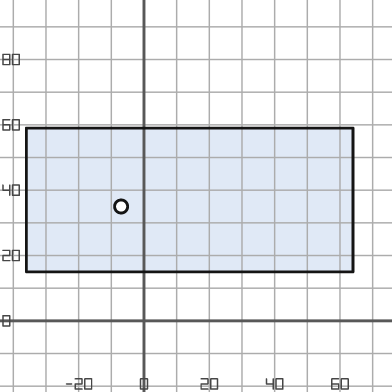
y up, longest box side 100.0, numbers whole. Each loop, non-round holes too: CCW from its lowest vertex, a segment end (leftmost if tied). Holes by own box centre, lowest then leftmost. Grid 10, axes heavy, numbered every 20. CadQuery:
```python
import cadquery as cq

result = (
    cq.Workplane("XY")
    .moveTo(-36.0, 15.0)
    .lineTo(64.0, 15.0)
    .lineTo(64.0, 59.0)
    .lineTo(-36.0, 59.0)
    .close()
    .moveTo(-7.0, 35.0)
    .circle(2.0)
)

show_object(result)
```